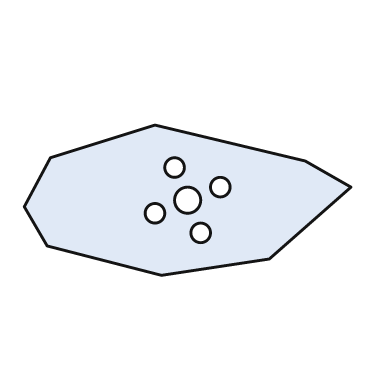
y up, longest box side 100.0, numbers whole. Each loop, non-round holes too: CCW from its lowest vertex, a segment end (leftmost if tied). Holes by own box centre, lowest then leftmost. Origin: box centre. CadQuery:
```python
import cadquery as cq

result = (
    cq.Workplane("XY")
    .moveTo(-8.0, -23.0)
    .lineTo(25.0, -18.0)
    .lineTo(50.0, 4.0)
    .lineTo(36.0, 12.0)
    .lineTo(-10.0, 23.0)
    .lineTo(-42.0, 13.0)
    .lineTo(-50.0, -2.0)
    .lineTo(-43.0, -14.0)
    .close()
    .moveTo(4.0, -10.0)
    .circle(3.0)
    .moveTo(-10.0, -4.0)
    .circle(3.0)
    .moveTo(0.0, 0.0)
    .circle(4.0)
    .moveTo(10.0, 4.0)
    .circle(3.0)
    .moveTo(-4.0, 10.0)
    .circle(3.0)
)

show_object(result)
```